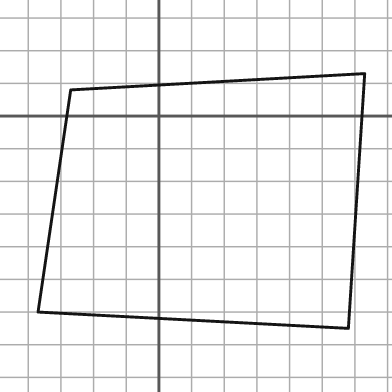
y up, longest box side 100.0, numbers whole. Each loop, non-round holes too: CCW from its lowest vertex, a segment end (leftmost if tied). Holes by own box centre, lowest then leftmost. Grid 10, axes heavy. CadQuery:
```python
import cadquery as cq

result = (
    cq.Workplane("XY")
    .moveTo(58.0, -65.0)
    .lineTo(63.0, 13.0)
    .lineTo(-27.0, 8.0)
    .lineTo(-37.0, -60.0)
    .close()
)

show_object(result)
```